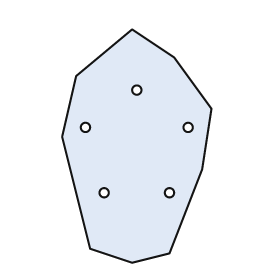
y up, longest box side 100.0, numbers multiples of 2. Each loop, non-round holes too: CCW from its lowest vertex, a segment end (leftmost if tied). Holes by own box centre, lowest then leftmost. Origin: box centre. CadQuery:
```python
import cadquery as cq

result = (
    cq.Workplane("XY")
    .moveTo(-2.0, -50.0)
    .lineTo(14.0, -46.0)
    .lineTo(28.0, -10.0)
    .lineTo(32.0, 16.0)
    .lineTo(16.0, 38.0)
    .lineTo(-2.0, 50.0)
    .lineTo(-26.0, 30.0)
    .lineTo(-32.0, 4.0)
    .lineTo(-20.0, -44.0)
    .close()
    .moveTo(-14.0, -20.0)
    .circle(2.0)
    .moveTo(14.0, -20.0)
    .circle(2.0)
    .moveTo(-22.0, 8.0)
    .circle(2.0)
    .moveTo(22.0, 8.0)
    .circle(2.0)
    .moveTo(0.0, 24.0)
    .circle(2.0)
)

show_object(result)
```